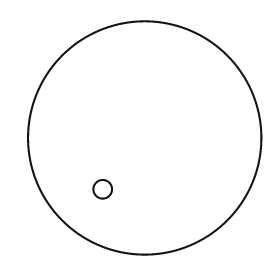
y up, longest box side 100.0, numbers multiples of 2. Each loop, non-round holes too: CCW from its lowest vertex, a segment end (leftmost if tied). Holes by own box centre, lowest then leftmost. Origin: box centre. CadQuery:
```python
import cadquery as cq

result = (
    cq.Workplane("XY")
    .moveTo(0.0, 0.0)
    .circle(50.0)
    .moveTo(-18.0, -22.0)
    .circle(4.0)
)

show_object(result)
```